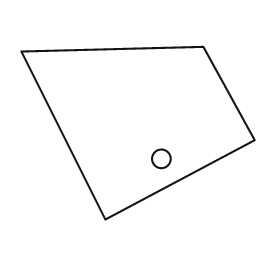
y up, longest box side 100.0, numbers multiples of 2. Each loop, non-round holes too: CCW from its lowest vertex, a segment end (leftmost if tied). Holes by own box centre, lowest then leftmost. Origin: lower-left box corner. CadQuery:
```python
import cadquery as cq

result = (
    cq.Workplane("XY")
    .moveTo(36.0, 0.0)
    .lineTo(100.0, 34.0)
    .lineTo(78.0, 74.0)
    .lineTo(0.0, 72.0)
    .close()
    .moveTo(60.0, 26.0)
    .circle(4.0)
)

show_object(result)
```